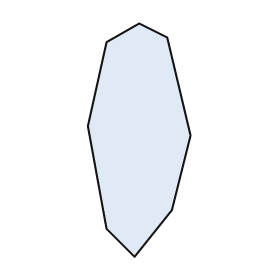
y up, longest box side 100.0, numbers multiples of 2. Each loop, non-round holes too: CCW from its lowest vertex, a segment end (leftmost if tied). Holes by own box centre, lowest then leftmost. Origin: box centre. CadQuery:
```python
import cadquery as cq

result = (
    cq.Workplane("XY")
    .moveTo(-2.0, -50.0)
    .lineTo(14.0, -30.0)
    .lineTo(22.0, 2.0)
    .lineTo(12.0, 44.0)
    .lineTo(0.0, 50.0)
    .lineTo(-14.0, 42.0)
    .lineTo(-22.0, 6.0)
    .lineTo(-14.0, -38.0)
    .close()
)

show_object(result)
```